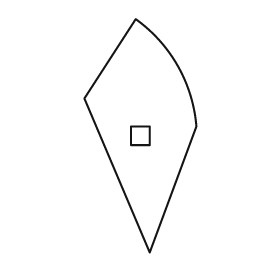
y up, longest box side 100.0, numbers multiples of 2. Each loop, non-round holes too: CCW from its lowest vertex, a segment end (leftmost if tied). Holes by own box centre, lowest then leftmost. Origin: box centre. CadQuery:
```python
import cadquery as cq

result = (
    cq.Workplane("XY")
    .moveTo(4.0, -50.0)
    .lineTo(24.0, 4.0)
    .threePointArc((16.0, 30.0), (-2.0, 50.0))
    .lineTo(-24.0, 16.0)
    .close()
    .moveTo(-4.0, -4.0)
    .lineTo(4.0, -4.0)
    .lineTo(4.0, 4.0)
    .lineTo(-4.0, 4.0)
    .close()
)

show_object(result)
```